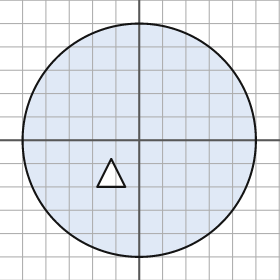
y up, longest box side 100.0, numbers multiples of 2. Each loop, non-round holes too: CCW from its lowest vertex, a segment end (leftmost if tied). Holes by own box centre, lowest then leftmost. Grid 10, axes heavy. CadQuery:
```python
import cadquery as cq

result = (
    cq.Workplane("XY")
    .moveTo(0.0, 0.0)
    .circle(50.0)
    .moveTo(-18.0, -20.0)
    .lineTo(-6.0, -20.0)
    .lineTo(-12.0, -8.0)
    .close()
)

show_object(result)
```